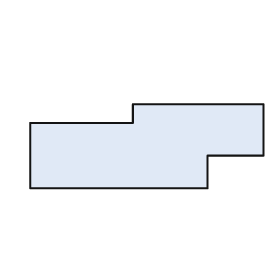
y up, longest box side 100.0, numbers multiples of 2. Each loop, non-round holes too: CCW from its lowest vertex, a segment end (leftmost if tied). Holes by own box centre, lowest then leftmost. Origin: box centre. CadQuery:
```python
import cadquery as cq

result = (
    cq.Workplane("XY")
    .moveTo(-50.0, -18.0)
    .lineTo(26.0, -18.0)
    .lineTo(26.0, -4.0)
    .lineTo(50.0, -4.0)
    .lineTo(50.0, 18.0)
    .lineTo(-6.0, 18.0)
    .lineTo(-6.0, 10.0)
    .lineTo(-50.0, 10.0)
    .close()
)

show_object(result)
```